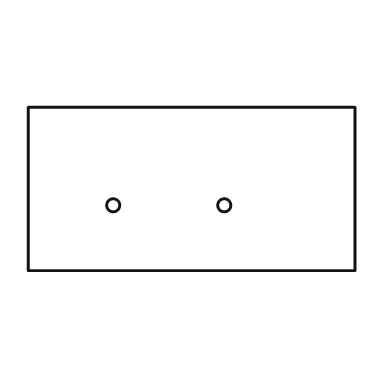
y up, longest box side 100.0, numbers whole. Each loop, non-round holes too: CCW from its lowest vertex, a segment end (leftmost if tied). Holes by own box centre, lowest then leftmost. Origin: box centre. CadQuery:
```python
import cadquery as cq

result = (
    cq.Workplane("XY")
    .moveTo(-50.0, -25.0)
    .lineTo(50.0, -25.0)
    .lineTo(50.0, 25.0)
    .lineTo(-50.0, 25.0)
    .close()
    .moveTo(-24.0, -5.0)
    .circle(2.0)
    .moveTo(10.0, -5.0)
    .circle(2.0)
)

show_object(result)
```